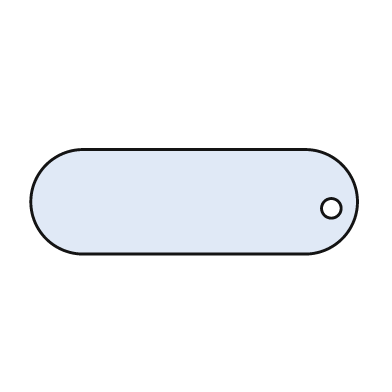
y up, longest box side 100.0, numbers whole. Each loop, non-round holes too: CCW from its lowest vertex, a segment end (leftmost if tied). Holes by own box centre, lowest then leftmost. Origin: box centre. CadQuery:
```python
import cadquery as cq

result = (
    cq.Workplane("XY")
    .moveTo(-34.0, -16.0)
    .lineTo(34.0, -16.0)
    .threePointArc((50.0, 0.0), (34.0, 16.0))
    .lineTo(-34.0, 16.0)
    .threePointArc((-50.0, 0.0), (-34.0, -16.0))
    .close()
    .moveTo(42.0, -2.0)
    .circle(3.0)
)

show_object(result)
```